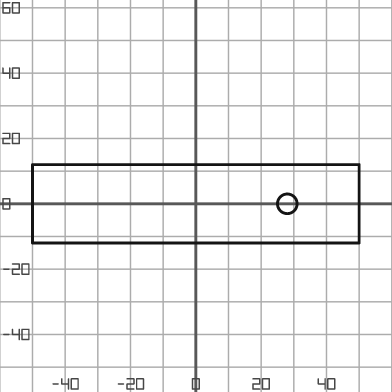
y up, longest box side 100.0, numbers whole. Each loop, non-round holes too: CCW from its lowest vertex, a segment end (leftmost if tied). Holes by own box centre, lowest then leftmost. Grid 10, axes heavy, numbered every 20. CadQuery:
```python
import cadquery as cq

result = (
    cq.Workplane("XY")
    .moveTo(-50.0, -12.0)
    .lineTo(50.0, -12.0)
    .lineTo(50.0, 12.0)
    .lineTo(-50.0, 12.0)
    .close()
    .moveTo(28.0, 0.0)
    .circle(3.0)
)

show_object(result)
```